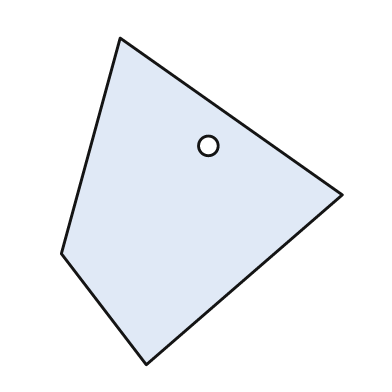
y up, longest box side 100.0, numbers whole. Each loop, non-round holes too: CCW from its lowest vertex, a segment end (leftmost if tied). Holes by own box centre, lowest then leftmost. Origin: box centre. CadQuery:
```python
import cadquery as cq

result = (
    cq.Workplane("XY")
    .moveTo(-17.0, -50.0)
    .lineTo(43.0, 2.0)
    .lineTo(-25.0, 50.0)
    .lineTo(-43.0, -16.0)
    .close()
    .moveTo(2.0, 17.0)
    .circle(3.0)
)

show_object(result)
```